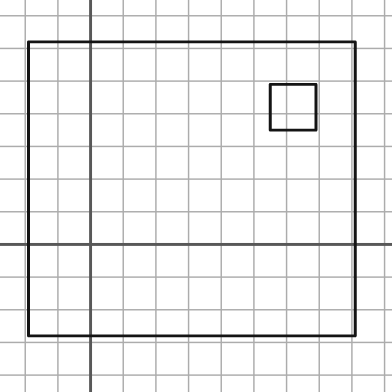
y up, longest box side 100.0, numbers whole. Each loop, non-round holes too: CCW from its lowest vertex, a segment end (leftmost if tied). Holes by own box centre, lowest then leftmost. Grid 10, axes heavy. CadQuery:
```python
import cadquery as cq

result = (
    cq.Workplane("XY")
    .moveTo(-19.0, -28.0)
    .lineTo(81.0, -28.0)
    .lineTo(81.0, 62.0)
    .lineTo(-19.0, 62.0)
    .close()
    .moveTo(55.0, 35.0)
    .lineTo(69.0, 35.0)
    .lineTo(69.0, 49.0)
    .lineTo(55.0, 49.0)
    .close()
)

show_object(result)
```